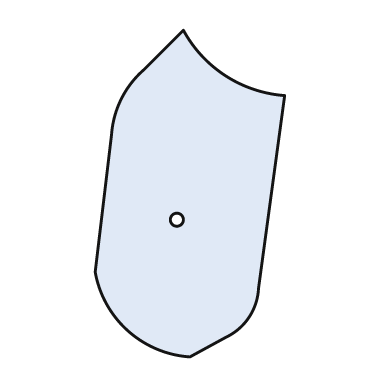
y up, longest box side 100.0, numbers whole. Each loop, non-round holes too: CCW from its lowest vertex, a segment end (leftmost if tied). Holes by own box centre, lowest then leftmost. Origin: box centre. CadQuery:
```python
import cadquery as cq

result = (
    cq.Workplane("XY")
    .moveTo(0.0, -50.0)
    .lineTo(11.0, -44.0)
    .threePointArc((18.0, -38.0), (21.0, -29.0))
    .lineTo(29.0, 30.0)
    .threePointArc((11.0, 36.0), (-2.0, 50.0))
    .lineTo(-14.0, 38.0)
    .threePointArc((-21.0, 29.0), (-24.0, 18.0))
    .lineTo(-29.0, -24.0)
    .threePointArc((-19.0, -42.0), (0.0, -50.0))
    .close()
    .moveTo(-4.0, -8.0)
    .circle(2.0)
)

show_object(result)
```